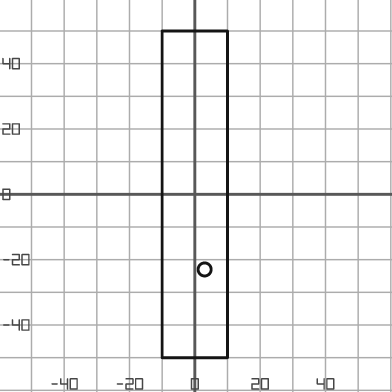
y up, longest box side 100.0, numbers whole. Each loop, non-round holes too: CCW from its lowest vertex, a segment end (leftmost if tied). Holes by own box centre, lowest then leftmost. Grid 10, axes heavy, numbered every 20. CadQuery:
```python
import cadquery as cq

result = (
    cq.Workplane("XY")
    .moveTo(-10.0, -50.0)
    .lineTo(10.0, -50.0)
    .lineTo(10.0, 50.0)
    .lineTo(-10.0, 50.0)
    .close()
    .moveTo(3.0, -23.0)
    .circle(2.0)
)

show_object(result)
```